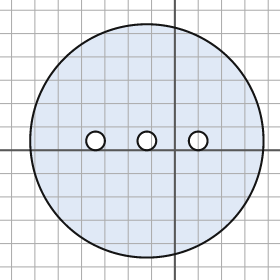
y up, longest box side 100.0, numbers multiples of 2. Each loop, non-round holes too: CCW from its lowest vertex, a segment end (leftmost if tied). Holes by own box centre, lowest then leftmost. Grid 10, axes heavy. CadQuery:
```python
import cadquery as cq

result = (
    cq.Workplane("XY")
    .moveTo(-12.0, 4.0)
    .circle(50.0)
    .moveTo(-34.0, 4.0)
    .circle(4.0)
    .moveTo(-12.0, 4.0)
    .circle(4.0)
    .moveTo(10.0, 4.0)
    .circle(4.0)
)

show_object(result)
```